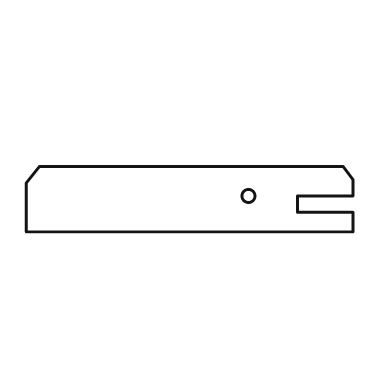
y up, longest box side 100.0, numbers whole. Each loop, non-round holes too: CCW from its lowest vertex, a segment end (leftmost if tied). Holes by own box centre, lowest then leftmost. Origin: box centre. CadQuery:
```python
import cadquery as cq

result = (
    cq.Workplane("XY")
    .moveTo(-50.0, -10.0)
    .lineTo(50.0, -10.0)
    .lineTo(50.0, -4.0)
    .lineTo(33.0, -4.0)
    .lineTo(33.0, 1.0)
    .lineTo(50.0, 1.0)
    .lineTo(50.0, 6.0)
    .lineTo(47.0, 10.0)
    .lineTo(-46.0, 10.0)
    .lineTo(-50.0, 5.0)
    .close()
    .moveTo(18.0, 1.0)
    .circle(2.0)
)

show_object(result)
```